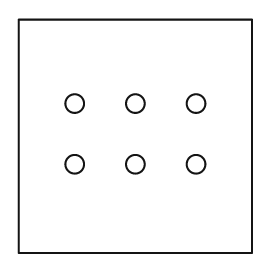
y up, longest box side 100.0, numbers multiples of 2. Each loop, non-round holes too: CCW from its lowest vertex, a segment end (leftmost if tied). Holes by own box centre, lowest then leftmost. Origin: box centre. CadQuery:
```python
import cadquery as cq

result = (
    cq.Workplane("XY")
    .moveTo(-50.0, -50.0)
    .lineTo(50.0, -50.0)
    .lineTo(50.0, 50.0)
    .lineTo(-50.0, 50.0)
    .close()
    .moveTo(-26.0, -12.0)
    .circle(4.0)
    .moveTo(0.0, -12.0)
    .circle(4.0)
    .moveTo(26.0, -12.0)
    .circle(4.0)
    .moveTo(-26.0, 14.0)
    .circle(4.0)
    .moveTo(0.0, 14.0)
    .circle(4.0)
    .moveTo(26.0, 14.0)
    .circle(4.0)
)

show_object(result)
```